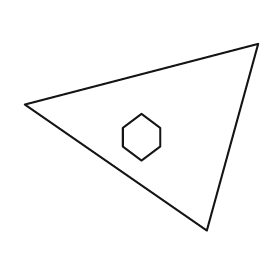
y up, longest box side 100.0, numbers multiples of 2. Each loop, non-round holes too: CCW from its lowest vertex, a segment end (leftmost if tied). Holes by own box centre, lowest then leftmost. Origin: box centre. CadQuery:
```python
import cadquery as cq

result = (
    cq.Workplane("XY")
    .moveTo(28.0, -40.0)
    .lineTo(50.0, 40.0)
    .lineTo(-50.0, 14.0)
    .close()
    .moveTo(0.0, -10.0)
    .lineTo(8.0, -4.0)
    .lineTo(8.0, 4.0)
    .lineTo(0.0, 10.0)
    .lineTo(-8.0, 4.0)
    .lineTo(-8.0, -4.0)
    .close()
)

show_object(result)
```